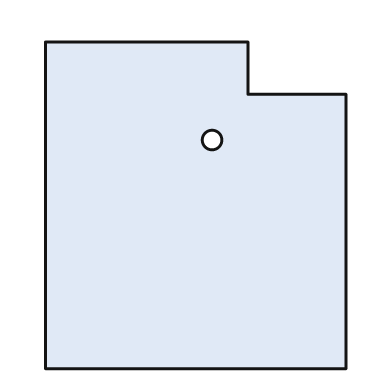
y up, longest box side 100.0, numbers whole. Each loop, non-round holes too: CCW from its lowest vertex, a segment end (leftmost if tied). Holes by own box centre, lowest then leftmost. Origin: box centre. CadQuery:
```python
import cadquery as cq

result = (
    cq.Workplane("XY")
    .moveTo(-46.0, -50.0)
    .lineTo(46.0, -50.0)
    .lineTo(46.0, 34.0)
    .lineTo(16.0, 34.0)
    .lineTo(16.0, 50.0)
    .lineTo(-46.0, 50.0)
    .close()
    .moveTo(5.0, 20.0)
    .circle(3.0)
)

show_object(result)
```